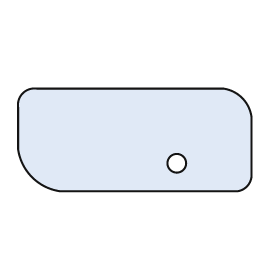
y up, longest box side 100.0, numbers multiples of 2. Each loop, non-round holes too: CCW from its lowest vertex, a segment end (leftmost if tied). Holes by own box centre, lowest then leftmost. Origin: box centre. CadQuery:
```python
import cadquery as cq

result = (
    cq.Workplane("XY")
    .moveTo(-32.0, -22.0)
    .lineTo(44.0, -22.0)
    .threePointArc((48.0, -20.0), (50.0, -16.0))
    .lineTo(50.0, 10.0)
    .threePointArc((46.0, 18.0), (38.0, 22.0))
    .lineTo(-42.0, 22.0)
    .threePointArc((-48.0, 20.0), (-50.0, 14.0))
    .lineTo(-50.0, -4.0)
    .threePointArc((-44.0, -16.0), (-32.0, -22.0))
    .close()
    .moveTo(18.0, -10.0)
    .circle(4.0)
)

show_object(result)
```